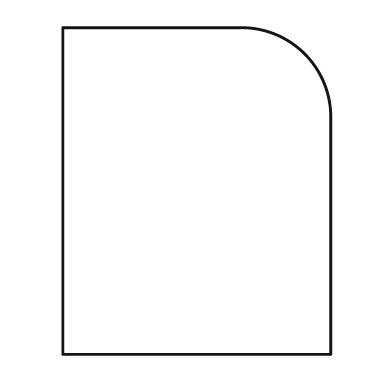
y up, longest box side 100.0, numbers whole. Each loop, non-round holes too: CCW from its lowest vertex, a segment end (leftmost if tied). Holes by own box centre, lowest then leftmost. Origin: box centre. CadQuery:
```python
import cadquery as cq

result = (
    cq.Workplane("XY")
    .moveTo(-41.0, -50.0)
    .lineTo(41.0, -50.0)
    .lineTo(41.0, 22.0)
    .threePointArc((33.0, 42.0), (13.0, 50.0))
    .lineTo(-41.0, 50.0)
    .close()
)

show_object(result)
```